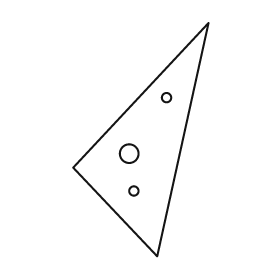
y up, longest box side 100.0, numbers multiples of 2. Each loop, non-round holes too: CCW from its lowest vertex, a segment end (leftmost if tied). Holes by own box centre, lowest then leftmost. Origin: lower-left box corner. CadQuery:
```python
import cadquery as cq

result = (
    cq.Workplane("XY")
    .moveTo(36.0, 0.0)
    .lineTo(58.0, 100.0)
    .lineTo(0.0, 38.0)
    .close()
    .moveTo(26.0, 28.0)
    .circle(2.0)
    .moveTo(24.0, 44.0)
    .circle(4.0)
    .moveTo(40.0, 68.0)
    .circle(2.0)
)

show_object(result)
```